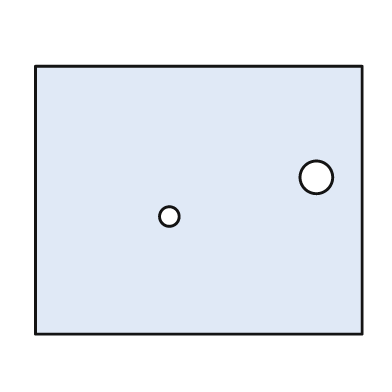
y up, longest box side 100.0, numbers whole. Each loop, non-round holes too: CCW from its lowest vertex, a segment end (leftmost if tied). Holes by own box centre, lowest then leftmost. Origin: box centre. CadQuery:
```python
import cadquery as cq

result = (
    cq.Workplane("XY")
    .moveTo(-50.0, -41.0)
    .lineTo(50.0, -41.0)
    .lineTo(50.0, 41.0)
    .lineTo(-50.0, 41.0)
    .close()
    .moveTo(-9.0, -5.0)
    .circle(3.0)
    .moveTo(36.0, 7.0)
    .circle(5.0)
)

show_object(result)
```